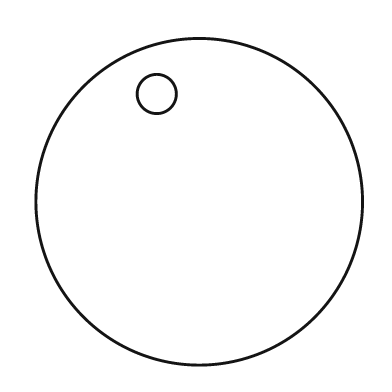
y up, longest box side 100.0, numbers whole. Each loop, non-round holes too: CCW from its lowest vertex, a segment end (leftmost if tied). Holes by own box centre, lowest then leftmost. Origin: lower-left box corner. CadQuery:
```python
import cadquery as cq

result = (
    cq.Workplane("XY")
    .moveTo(50.0, 50.0)
    .circle(50.0)
    .moveTo(37.0, 83.0)
    .circle(6.0)
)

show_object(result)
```